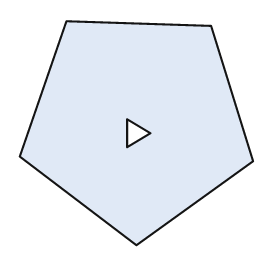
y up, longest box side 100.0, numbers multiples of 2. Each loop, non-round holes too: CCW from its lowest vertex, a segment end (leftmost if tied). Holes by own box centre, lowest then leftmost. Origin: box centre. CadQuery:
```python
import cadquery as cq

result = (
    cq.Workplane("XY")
    .moveTo(0.0, -48.0)
    .lineTo(50.0, -12.0)
    .lineTo(32.0, 46.0)
    .lineTo(-30.0, 48.0)
    .lineTo(-50.0, -10.0)
    .close()
    .moveTo(-4.0, -6.0)
    .lineTo(6.0, 0.0)
    .lineTo(-4.0, 6.0)
    .close()
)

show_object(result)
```